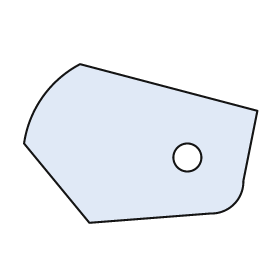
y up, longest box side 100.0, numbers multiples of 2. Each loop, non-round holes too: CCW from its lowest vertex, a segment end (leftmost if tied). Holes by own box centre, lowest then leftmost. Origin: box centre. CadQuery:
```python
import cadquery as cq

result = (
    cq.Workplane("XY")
    .moveTo(-22.0, -34.0)
    .lineTo(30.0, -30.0)
    .threePointArc((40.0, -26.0), (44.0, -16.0))
    .lineTo(50.0, 14.0)
    .lineTo(-26.0, 34.0)
    .threePointArc((-42.0, 20.0), (-50.0, 0.0))
    .close()
    .moveTo(20.0, -6.0)
    .circle(6.0)
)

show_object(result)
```